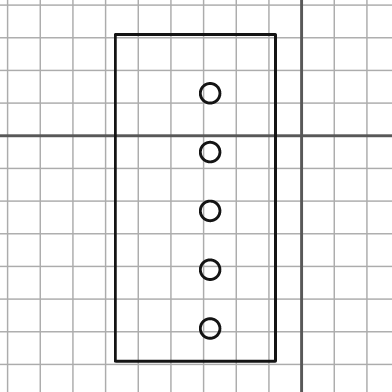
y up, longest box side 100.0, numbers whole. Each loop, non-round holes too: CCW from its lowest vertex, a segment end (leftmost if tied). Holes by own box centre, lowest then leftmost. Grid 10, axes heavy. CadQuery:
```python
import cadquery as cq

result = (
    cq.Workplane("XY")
    .moveTo(-57.0, -69.0)
    .lineTo(-8.0, -69.0)
    .lineTo(-8.0, 31.0)
    .lineTo(-57.0, 31.0)
    .close()
    .moveTo(-28.0, -59.0)
    .circle(3.0)
    .moveTo(-28.0, -41.0)
    .circle(3.0)
    .moveTo(-28.0, -23.0)
    .circle(3.0)
    .moveTo(-28.0, -5.0)
    .circle(3.0)
    .moveTo(-28.0, 13.0)
    .circle(3.0)
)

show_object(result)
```